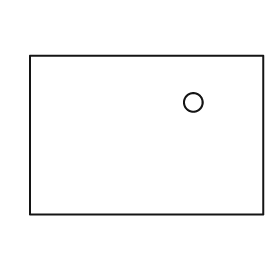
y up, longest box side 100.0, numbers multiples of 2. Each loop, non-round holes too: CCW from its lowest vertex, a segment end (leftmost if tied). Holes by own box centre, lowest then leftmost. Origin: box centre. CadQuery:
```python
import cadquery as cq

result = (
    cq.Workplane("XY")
    .moveTo(-50.0, -34.0)
    .lineTo(50.0, -34.0)
    .lineTo(50.0, 34.0)
    .lineTo(-50.0, 34.0)
    .close()
    .moveTo(20.0, 14.0)
    .circle(4.0)
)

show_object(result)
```